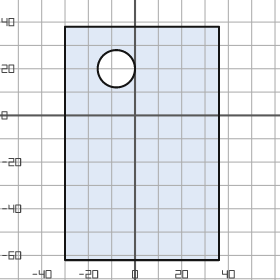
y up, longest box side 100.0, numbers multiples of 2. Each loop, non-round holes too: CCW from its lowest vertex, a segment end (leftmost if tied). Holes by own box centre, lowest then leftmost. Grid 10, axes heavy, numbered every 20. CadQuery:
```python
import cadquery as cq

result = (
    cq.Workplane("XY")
    .moveTo(-30.0, -62.0)
    .lineTo(36.0, -62.0)
    .lineTo(36.0, 38.0)
    .lineTo(-30.0, 38.0)
    .close()
    .moveTo(-8.0, 20.0)
    .circle(8.0)
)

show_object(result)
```